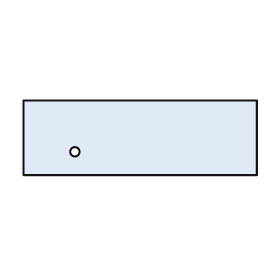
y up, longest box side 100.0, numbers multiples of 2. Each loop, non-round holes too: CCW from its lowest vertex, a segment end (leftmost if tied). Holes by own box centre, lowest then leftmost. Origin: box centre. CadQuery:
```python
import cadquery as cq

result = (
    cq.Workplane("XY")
    .moveTo(-50.0, -16.0)
    .lineTo(50.0, -16.0)
    .lineTo(50.0, 16.0)
    .lineTo(-50.0, 16.0)
    .close()
    .moveTo(-28.0, -6.0)
    .circle(2.0)
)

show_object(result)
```